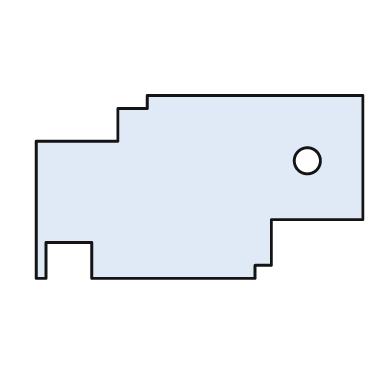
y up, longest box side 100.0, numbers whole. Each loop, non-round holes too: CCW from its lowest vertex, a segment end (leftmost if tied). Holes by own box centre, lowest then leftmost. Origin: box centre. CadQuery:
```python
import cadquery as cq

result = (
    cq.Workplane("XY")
    .moveTo(-50.0, -28.0)
    .lineTo(-47.0, -28.0)
    .lineTo(-47.0, -17.0)
    .lineTo(-33.0, -17.0)
    .lineTo(-33.0, -28.0)
    .lineTo(17.0, -28.0)
    .lineTo(17.0, -24.0)
    .lineTo(22.0, -24.0)
    .lineTo(22.0, -10.0)
    .lineTo(50.0, -10.0)
    .lineTo(50.0, 28.0)
    .lineTo(-16.0, 28.0)
    .lineTo(-16.0, 24.0)
    .lineTo(-25.0, 24.0)
    .lineTo(-25.0, 14.0)
    .lineTo(-50.0, 14.0)
    .close()
    .moveTo(33.0, 8.0)
    .circle(4.0)
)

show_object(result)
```